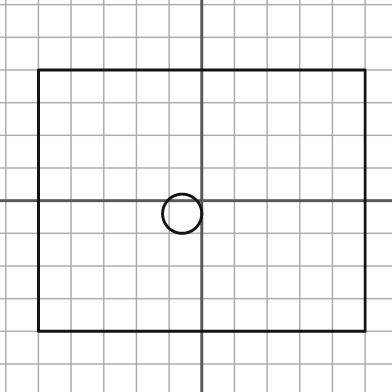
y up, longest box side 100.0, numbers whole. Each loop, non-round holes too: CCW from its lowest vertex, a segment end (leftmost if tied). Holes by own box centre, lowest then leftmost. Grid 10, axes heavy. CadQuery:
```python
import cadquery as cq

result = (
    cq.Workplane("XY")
    .moveTo(-50.0, -40.0)
    .lineTo(50.0, -40.0)
    .lineTo(50.0, 40.0)
    .lineTo(-50.0, 40.0)
    .close()
    .moveTo(-6.0, -4.0)
    .circle(6.0)
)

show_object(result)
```